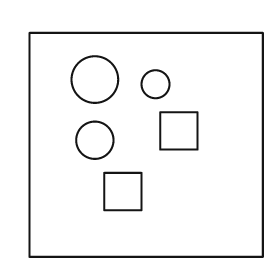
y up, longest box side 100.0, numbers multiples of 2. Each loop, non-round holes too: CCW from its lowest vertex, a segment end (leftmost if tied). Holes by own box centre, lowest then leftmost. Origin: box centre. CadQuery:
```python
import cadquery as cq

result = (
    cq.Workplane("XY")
    .moveTo(-50.0, -48.0)
    .lineTo(50.0, -48.0)
    .lineTo(50.0, 48.0)
    .lineTo(-50.0, 48.0)
    .close()
    .moveTo(-18.0, -28.0)
    .lineTo(-2.0, -28.0)
    .lineTo(-2.0, -12.0)
    .lineTo(-18.0, -12.0)
    .close()
    .moveTo(-22.0, 2.0)
    .circle(8.0)
    .moveTo(6.0, -2.0)
    .lineTo(22.0, -2.0)
    .lineTo(22.0, 14.0)
    .lineTo(6.0, 14.0)
    .close()
    .moveTo(4.0, 26.0)
    .circle(6.0)
    .moveTo(-22.0, 28.0)
    .circle(10.0)
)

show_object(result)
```